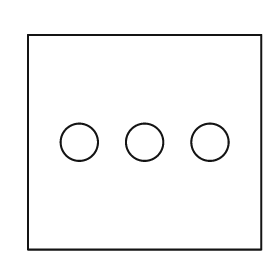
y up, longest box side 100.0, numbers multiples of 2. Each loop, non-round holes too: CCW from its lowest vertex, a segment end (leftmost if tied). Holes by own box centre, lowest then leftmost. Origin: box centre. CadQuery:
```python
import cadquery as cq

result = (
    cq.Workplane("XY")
    .moveTo(-50.0, -46.0)
    .lineTo(50.0, -46.0)
    .lineTo(50.0, 46.0)
    .lineTo(-50.0, 46.0)
    .close()
    .moveTo(-28.0, 0.0)
    .circle(8.0)
    .moveTo(0.0, 0.0)
    .circle(8.0)
    .moveTo(28.0, 0.0)
    .circle(8.0)
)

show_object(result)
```